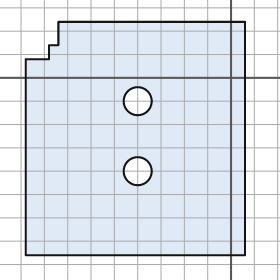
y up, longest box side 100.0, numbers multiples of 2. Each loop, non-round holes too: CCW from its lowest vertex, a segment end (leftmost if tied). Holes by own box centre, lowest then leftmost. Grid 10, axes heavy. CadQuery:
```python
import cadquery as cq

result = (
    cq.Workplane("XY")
    .moveTo(-88.0, -76.0)
    .lineTo(6.0, -76.0)
    .lineTo(6.0, 24.0)
    .lineTo(-74.0, 24.0)
    .lineTo(-74.0, 14.0)
    .lineTo(-78.0, 14.0)
    .lineTo(-78.0, 8.0)
    .lineTo(-88.0, 8.0)
    .close()
    .moveTo(-40.0, -40.0)
    .circle(6.0)
    .moveTo(-40.0, -10.0)
    .circle(6.0)
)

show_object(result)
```